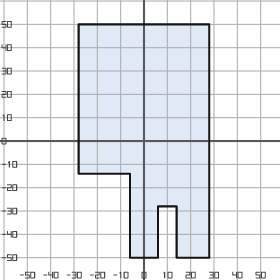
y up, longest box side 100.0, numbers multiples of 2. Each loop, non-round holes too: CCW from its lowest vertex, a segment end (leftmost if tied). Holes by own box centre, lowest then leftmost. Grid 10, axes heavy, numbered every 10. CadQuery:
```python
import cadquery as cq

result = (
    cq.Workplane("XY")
    .moveTo(-6.0, -50.0)
    .lineTo(6.0, -50.0)
    .lineTo(6.0, -28.0)
    .lineTo(14.0, -28.0)
    .lineTo(14.0, -50.0)
    .lineTo(28.0, -50.0)
    .lineTo(28.0, 50.0)
    .lineTo(-28.0, 50.0)
    .lineTo(-28.0, -14.0)
    .lineTo(-6.0, -14.0)
    .close()
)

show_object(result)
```